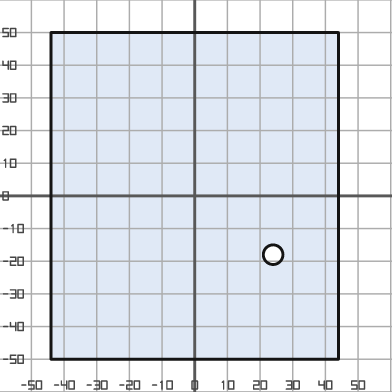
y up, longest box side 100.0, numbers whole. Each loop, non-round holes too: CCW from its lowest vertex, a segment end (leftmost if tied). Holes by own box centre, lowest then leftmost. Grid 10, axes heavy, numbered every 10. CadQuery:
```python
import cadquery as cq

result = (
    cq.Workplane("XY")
    .moveTo(-44.0, -50.0)
    .lineTo(44.0, -50.0)
    .lineTo(44.0, 50.0)
    .lineTo(-44.0, 50.0)
    .close()
    .moveTo(24.0, -18.0)
    .circle(3.0)
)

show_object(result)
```